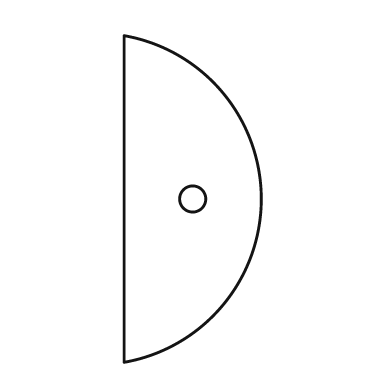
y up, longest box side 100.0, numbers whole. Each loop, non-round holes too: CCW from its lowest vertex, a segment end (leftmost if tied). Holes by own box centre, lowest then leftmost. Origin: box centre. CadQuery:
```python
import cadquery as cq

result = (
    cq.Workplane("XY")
    .moveTo(-21.0, -50.0)
    .threePointArc((21.0, 0.0), (-21.0, 50.0))
    .close()
    .moveTo(0.0, 0.0)
    .circle(4.0)
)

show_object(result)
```